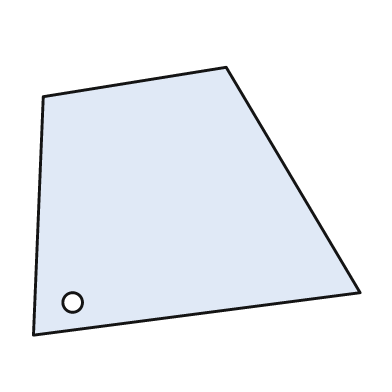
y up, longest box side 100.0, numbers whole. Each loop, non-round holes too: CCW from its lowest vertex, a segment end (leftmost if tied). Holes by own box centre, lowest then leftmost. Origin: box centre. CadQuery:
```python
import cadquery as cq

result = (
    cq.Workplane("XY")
    .moveTo(-50.0, -41.0)
    .lineTo(50.0, -28.0)
    .lineTo(9.0, 41.0)
    .lineTo(-47.0, 32.0)
    .close()
    .moveTo(-38.0, -31.0)
    .circle(3.0)
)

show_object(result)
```